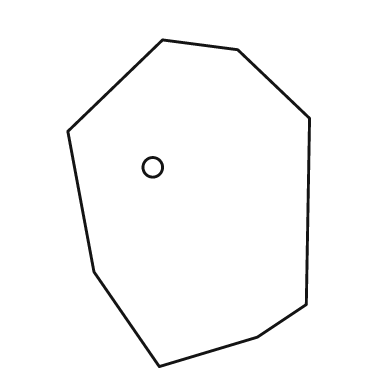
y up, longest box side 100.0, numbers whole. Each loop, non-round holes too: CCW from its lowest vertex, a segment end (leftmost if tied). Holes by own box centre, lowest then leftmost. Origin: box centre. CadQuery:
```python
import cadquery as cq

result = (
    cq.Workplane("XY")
    .moveTo(-9.0, -50.0)
    .lineTo(21.0, -41.0)
    .lineTo(36.0, -31.0)
    .lineTo(37.0, 26.0)
    .lineTo(15.0, 47.0)
    .lineTo(-8.0, 50.0)
    .lineTo(-37.0, 22.0)
    .lineTo(-29.0, -21.0)
    .close()
    .moveTo(-11.0, 11.0)
    .circle(3.0)
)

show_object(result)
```